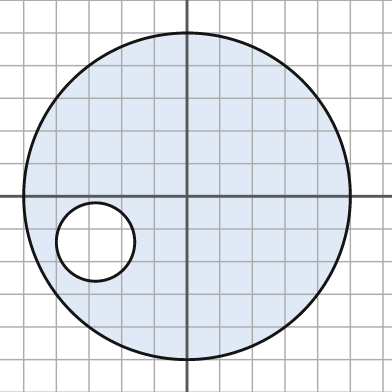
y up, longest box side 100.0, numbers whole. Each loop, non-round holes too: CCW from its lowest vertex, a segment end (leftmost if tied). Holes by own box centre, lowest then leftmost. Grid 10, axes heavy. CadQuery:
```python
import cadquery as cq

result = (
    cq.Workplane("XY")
    .moveTo(0.0, 0.0)
    .circle(50.0)
    .moveTo(-28.0, -14.0)
    .circle(12.0)
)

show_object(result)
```